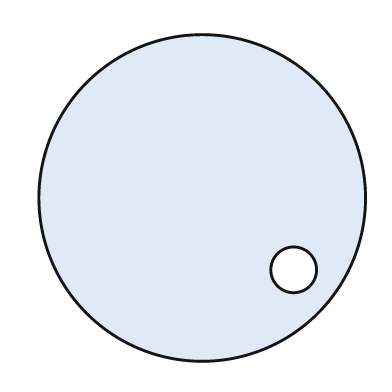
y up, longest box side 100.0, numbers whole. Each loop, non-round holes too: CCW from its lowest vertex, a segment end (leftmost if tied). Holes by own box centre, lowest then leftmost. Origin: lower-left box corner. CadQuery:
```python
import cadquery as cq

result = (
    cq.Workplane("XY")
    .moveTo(50.0, 50.0)
    .circle(50.0)
    .moveTo(78.0, 28.0)
    .circle(7.0)
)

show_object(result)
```